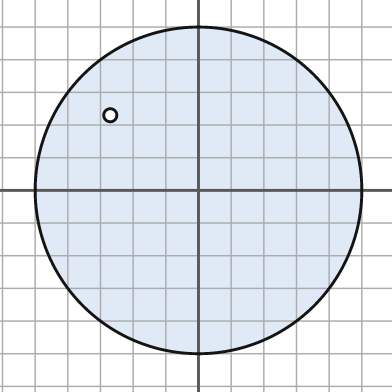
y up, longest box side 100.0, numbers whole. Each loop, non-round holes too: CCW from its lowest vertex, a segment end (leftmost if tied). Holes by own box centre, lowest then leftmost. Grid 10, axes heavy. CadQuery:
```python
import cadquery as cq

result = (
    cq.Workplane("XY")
    .moveTo(0.0, 0.0)
    .circle(50.0)
    .moveTo(-27.0, 23.0)
    .circle(2.0)
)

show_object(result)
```